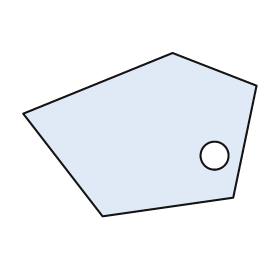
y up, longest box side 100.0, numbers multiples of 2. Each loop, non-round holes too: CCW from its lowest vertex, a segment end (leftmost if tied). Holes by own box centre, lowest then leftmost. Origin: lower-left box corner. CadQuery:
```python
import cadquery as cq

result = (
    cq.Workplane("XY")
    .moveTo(34.0, 0.0)
    .lineTo(90.0, 8.0)
    .lineTo(100.0, 56.0)
    .lineTo(64.0, 70.0)
    .lineTo(0.0, 44.0)
    .close()
    .moveTo(82.0, 26.0)
    .circle(6.0)
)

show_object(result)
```